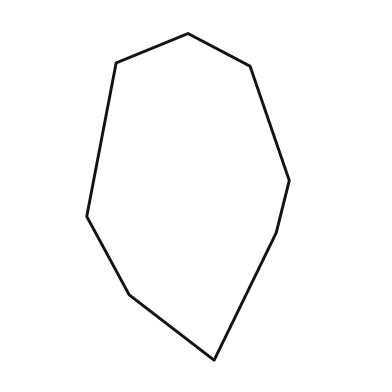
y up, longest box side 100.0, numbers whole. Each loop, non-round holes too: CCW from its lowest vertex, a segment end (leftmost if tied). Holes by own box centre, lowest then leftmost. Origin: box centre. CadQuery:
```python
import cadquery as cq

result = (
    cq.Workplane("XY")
    .moveTo(8.0, -50.0)
    .lineTo(27.0, -11.0)
    .lineTo(31.0, 5.0)
    .lineTo(19.0, 40.0)
    .lineTo(0.0, 50.0)
    .lineTo(-22.0, 41.0)
    .lineTo(-31.0, -6.0)
    .lineTo(-18.0, -30.0)
    .close()
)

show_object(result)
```